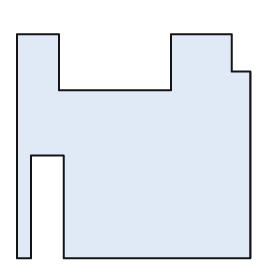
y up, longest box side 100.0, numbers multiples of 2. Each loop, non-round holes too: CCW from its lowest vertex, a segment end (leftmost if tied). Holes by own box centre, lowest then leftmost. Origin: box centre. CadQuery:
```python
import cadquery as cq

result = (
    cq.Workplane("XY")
    .moveTo(-50.0, -48.0)
    .lineTo(-44.0, -48.0)
    .lineTo(-44.0, -4.0)
    .lineTo(-30.0, -4.0)
    .lineTo(-30.0, -48.0)
    .lineTo(50.0, -48.0)
    .lineTo(50.0, 32.0)
    .lineTo(42.0, 32.0)
    .lineTo(42.0, 48.0)
    .lineTo(16.0, 48.0)
    .lineTo(16.0, 24.0)
    .lineTo(-32.0, 24.0)
    .lineTo(-32.0, 48.0)
    .lineTo(-50.0, 48.0)
    .close()
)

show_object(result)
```